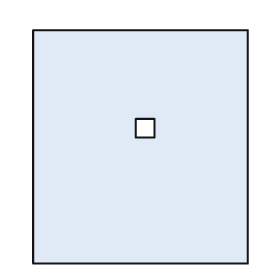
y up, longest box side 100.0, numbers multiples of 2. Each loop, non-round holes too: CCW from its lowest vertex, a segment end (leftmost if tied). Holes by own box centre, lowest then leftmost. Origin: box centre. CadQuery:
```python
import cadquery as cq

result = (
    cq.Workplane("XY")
    .moveTo(-46.0, -50.0)
    .lineTo(46.0, -50.0)
    .lineTo(46.0, 50.0)
    .lineTo(-46.0, 50.0)
    .close()
    .moveTo(-2.0, 4.0)
    .lineTo(6.0, 4.0)
    .lineTo(6.0, 12.0)
    .lineTo(-2.0, 12.0)
    .close()
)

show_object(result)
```